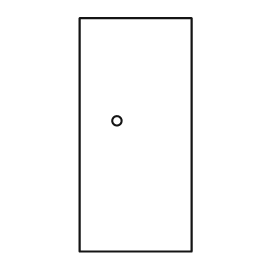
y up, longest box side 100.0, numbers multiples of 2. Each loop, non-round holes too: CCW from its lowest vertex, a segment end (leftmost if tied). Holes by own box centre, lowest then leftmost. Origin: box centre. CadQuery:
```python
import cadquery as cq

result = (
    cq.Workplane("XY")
    .moveTo(-24.0, -50.0)
    .lineTo(24.0, -50.0)
    .lineTo(24.0, 50.0)
    .lineTo(-24.0, 50.0)
    .close()
    .moveTo(-8.0, 6.0)
    .circle(2.0)
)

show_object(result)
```